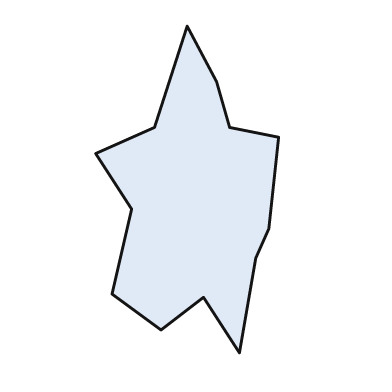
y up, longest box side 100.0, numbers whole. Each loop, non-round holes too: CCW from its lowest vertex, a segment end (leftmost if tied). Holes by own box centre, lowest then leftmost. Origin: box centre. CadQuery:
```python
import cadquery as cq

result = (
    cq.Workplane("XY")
    .moveTo(16.0, -50.0)
    .lineTo(21.0, -21.0)
    .lineTo(25.0, -12.0)
    .lineTo(28.0, 16.0)
    .lineTo(13.0, 19.0)
    .lineTo(9.0, 33.0)
    .lineTo(0.0, 50.0)
    .lineTo(-10.0, 19.0)
    .lineTo(-28.0, 11.0)
    .lineTo(-17.0, -6.0)
    .lineTo(-23.0, -32.0)
    .lineTo(-8.0, -43.0)
    .lineTo(5.0, -33.0)
    .close()
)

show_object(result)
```